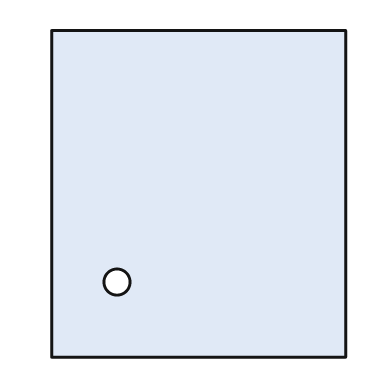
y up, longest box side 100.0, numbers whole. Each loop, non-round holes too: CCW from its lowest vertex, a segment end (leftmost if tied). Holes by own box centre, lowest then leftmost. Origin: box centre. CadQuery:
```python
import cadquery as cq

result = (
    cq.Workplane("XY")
    .moveTo(-45.0, -50.0)
    .lineTo(45.0, -50.0)
    .lineTo(45.0, 50.0)
    .lineTo(-45.0, 50.0)
    .close()
    .moveTo(-25.0, -27.0)
    .circle(4.0)
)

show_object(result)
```